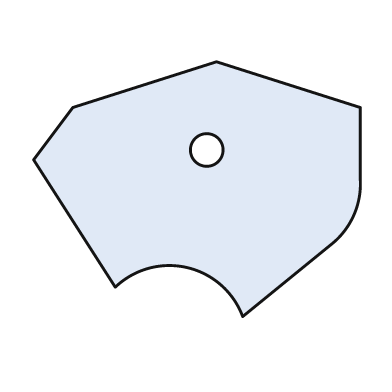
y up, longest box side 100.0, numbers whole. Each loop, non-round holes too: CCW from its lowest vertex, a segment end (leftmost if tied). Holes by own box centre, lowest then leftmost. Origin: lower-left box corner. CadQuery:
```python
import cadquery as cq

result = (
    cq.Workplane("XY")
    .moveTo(64.0, 0.0)
    .lineTo(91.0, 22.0)
    .threePointArc((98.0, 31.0), (100.0, 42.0))
    .lineTo(100.0, 64.0)
    .lineTo(56.0, 78.0)
    .lineTo(12.0, 64.0)
    .lineTo(0.0, 48.0)
    .lineTo(25.0, 9.0)
    .threePointArc((47.0, 15.0), (64.0, 0.0))
    .close()
    .moveTo(53.0, 51.0)
    .circle(5.0)
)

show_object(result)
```